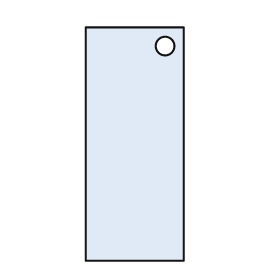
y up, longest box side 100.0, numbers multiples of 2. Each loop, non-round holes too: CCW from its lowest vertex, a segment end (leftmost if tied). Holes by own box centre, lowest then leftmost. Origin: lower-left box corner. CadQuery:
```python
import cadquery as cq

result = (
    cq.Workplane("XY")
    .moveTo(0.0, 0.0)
    .lineTo(42.0, 0.0)
    .lineTo(42.0, 100.0)
    .lineTo(0.0, 100.0)
    .close()
    .moveTo(34.0, 92.0)
    .circle(4.0)
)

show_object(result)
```